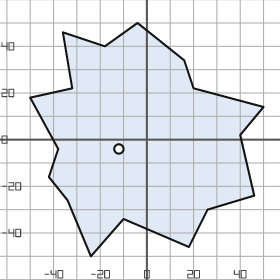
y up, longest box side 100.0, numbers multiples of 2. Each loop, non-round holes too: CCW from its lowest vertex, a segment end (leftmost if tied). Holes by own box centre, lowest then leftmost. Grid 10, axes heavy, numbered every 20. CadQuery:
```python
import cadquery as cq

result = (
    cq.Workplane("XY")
    .moveTo(-24.0, -50.0)
    .lineTo(-10.0, -34.0)
    .lineTo(18.0, -46.0)
    .lineTo(26.0, -30.0)
    .lineTo(46.0, -24.0)
    .lineTo(40.0, 2.0)
    .lineTo(50.0, 14.0)
    .lineTo(20.0, 22.0)
    .lineTo(16.0, 34.0)
    .lineTo(-4.0, 50.0)
    .lineTo(-18.0, 40.0)
    .lineTo(-36.0, 46.0)
    .lineTo(-32.0, 22.0)
    .lineTo(-50.0, 18.0)
    .lineTo(-38.0, -4.0)
    .lineTo(-42.0, -16.0)
    .lineTo(-34.0, -26.0)
    .close()
    .moveTo(-12.0, -4.0)
    .circle(2.0)
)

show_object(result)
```